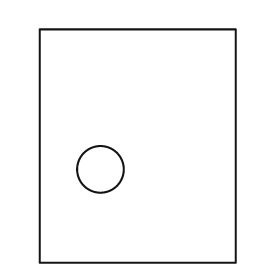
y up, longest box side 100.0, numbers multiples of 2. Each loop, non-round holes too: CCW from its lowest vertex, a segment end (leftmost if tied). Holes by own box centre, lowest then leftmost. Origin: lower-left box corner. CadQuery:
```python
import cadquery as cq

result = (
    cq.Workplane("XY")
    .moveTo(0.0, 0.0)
    .lineTo(84.0, 0.0)
    .lineTo(84.0, 100.0)
    .lineTo(0.0, 100.0)
    .close()
    .moveTo(26.0, 40.0)
    .circle(10.0)
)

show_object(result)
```